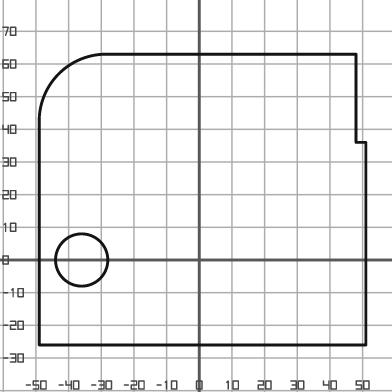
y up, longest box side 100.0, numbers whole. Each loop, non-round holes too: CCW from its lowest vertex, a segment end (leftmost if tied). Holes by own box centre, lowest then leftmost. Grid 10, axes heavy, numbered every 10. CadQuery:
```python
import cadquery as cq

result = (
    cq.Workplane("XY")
    .moveTo(-49.0, -26.0)
    .lineTo(51.0, -26.0)
    .lineTo(51.0, 36.0)
    .lineTo(48.0, 36.0)
    .lineTo(48.0, 63.0)
    .lineTo(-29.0, 63.0)
    .threePointArc((-43.0, 57.0), (-49.0, 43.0))
    .close()
    .moveTo(-36.0, 0.0)
    .circle(8.0)
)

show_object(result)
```